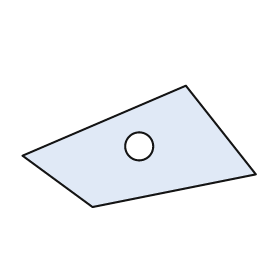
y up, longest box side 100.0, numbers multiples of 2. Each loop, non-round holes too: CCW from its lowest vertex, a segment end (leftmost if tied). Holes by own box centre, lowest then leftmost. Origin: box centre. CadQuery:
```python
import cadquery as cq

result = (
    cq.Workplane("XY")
    .moveTo(-20.0, -26.0)
    .lineTo(50.0, -12.0)
    .lineTo(20.0, 26.0)
    .lineTo(-50.0, -4.0)
    .close()
    .moveTo(0.0, 0.0)
    .circle(6.0)
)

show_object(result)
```